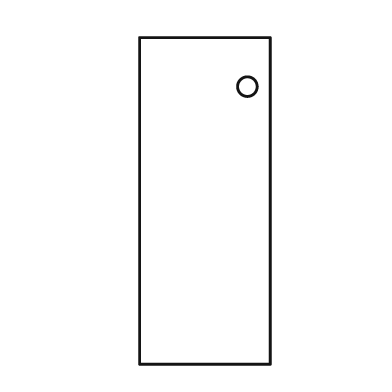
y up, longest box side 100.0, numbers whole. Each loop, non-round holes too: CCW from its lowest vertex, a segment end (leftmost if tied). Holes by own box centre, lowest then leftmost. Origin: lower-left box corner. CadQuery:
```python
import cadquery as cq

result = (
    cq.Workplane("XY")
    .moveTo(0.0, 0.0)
    .lineTo(40.0, 0.0)
    .lineTo(40.0, 100.0)
    .lineTo(0.0, 100.0)
    .close()
    .moveTo(33.0, 85.0)
    .circle(3.0)
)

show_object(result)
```